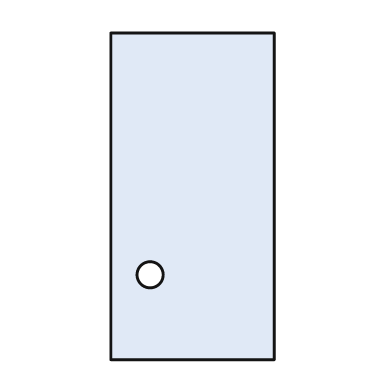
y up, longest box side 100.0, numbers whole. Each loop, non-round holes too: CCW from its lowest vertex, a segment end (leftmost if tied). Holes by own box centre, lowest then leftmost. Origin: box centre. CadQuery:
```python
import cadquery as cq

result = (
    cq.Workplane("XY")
    .moveTo(-25.0, -50.0)
    .lineTo(25.0, -50.0)
    .lineTo(25.0, 50.0)
    .lineTo(-25.0, 50.0)
    .close()
    .moveTo(-13.0, -24.0)
    .circle(4.0)
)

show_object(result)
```